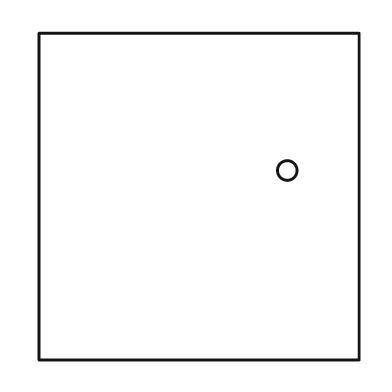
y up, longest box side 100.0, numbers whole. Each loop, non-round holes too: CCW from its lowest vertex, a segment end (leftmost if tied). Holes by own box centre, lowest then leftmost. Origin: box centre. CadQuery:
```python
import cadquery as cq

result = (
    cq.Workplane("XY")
    .moveTo(-49.0, -50.0)
    .lineTo(49.0, -50.0)
    .lineTo(49.0, 50.0)
    .lineTo(-49.0, 50.0)
    .close()
    .moveTo(27.0, 8.0)
    .circle(3.0)
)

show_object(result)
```